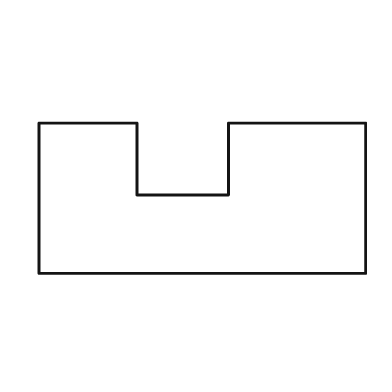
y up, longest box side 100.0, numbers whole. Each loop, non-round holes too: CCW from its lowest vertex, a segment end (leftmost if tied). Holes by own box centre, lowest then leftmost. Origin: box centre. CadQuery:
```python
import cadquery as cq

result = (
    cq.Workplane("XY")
    .moveTo(-50.0, -23.0)
    .lineTo(50.0, -23.0)
    .lineTo(50.0, 23.0)
    .lineTo(8.0, 23.0)
    .lineTo(8.0, 1.0)
    .lineTo(-20.0, 1.0)
    .lineTo(-20.0, 23.0)
    .lineTo(-50.0, 23.0)
    .close()
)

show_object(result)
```